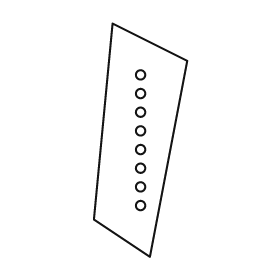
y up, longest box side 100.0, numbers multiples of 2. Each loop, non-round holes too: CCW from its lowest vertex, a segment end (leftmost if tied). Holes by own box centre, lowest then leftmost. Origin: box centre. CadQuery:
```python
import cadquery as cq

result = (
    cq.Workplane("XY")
    .moveTo(4.0, -50.0)
    .lineTo(20.0, 34.0)
    .lineTo(-12.0, 50.0)
    .lineTo(-20.0, -34.0)
    .close()
    .moveTo(0.0, -28.0)
    .circle(2.0)
    .moveTo(0.0, -20.0)
    .circle(2.0)
    .moveTo(0.0, -12.0)
    .circle(2.0)
    .moveTo(0.0, -4.0)
    .circle(2.0)
    .moveTo(0.0, 4.0)
    .circle(2.0)
    .moveTo(0.0, 12.0)
    .circle(2.0)
    .moveTo(0.0, 20.0)
    .circle(2.0)
    .moveTo(0.0, 28.0)
    .circle(2.0)
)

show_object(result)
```